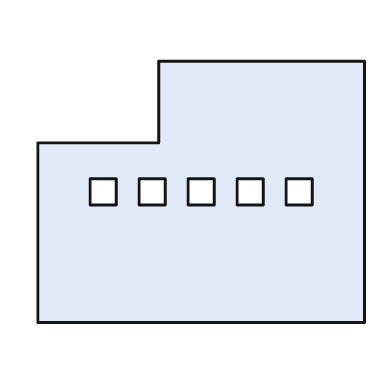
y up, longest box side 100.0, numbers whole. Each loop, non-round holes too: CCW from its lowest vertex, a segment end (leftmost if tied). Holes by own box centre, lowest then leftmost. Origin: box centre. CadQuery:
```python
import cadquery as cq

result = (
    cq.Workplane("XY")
    .moveTo(-50.0, -40.0)
    .lineTo(50.0, -40.0)
    .lineTo(50.0, 40.0)
    .lineTo(-13.0, 40.0)
    .lineTo(-13.0, 15.0)
    .lineTo(-50.0, 15.0)
    .close()
    .moveTo(-34.0, -4.0)
    .lineTo(-26.0, -4.0)
    .lineTo(-26.0, 4.0)
    .lineTo(-34.0, 4.0)
    .close()
    .moveTo(-19.0, -4.0)
    .lineTo(-11.0, -4.0)
    .lineTo(-11.0, 4.0)
    .lineTo(-19.0, 4.0)
    .close()
    .moveTo(-4.0, -4.0)
    .lineTo(4.0, -4.0)
    .lineTo(4.0, 4.0)
    .lineTo(-4.0, 4.0)
    .close()
    .moveTo(11.0, -4.0)
    .lineTo(19.0, -4.0)
    .lineTo(19.0, 4.0)
    .lineTo(11.0, 4.0)
    .close()
    .moveTo(26.0, -4.0)
    .lineTo(34.0, -4.0)
    .lineTo(34.0, 4.0)
    .lineTo(26.0, 4.0)
    .close()
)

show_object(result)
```